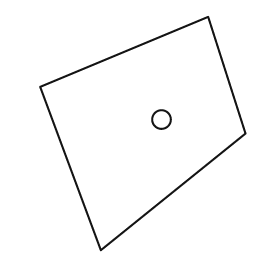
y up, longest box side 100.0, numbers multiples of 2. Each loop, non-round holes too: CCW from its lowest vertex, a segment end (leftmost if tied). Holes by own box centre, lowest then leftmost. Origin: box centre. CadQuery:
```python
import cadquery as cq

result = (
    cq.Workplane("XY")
    .moveTo(-18.0, -50.0)
    .lineTo(44.0, 0.0)
    .lineTo(28.0, 50.0)
    .lineTo(-44.0, 20.0)
    .close()
    .moveTo(8.0, 6.0)
    .circle(4.0)
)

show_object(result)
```